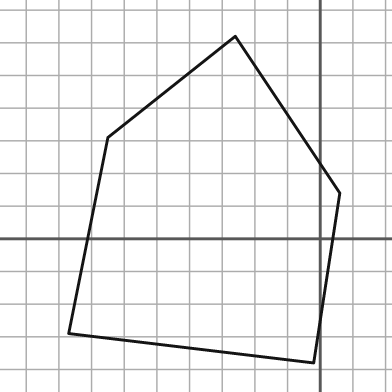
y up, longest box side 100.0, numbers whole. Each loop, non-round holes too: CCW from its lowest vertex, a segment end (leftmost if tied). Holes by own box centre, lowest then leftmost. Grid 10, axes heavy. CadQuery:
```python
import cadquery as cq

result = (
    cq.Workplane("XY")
    .moveTo(-2.0, -38.0)
    .lineTo(6.0, 14.0)
    .lineTo(-26.0, 62.0)
    .lineTo(-65.0, 31.0)
    .lineTo(-77.0, -29.0)
    .close()
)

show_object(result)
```